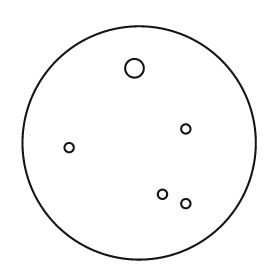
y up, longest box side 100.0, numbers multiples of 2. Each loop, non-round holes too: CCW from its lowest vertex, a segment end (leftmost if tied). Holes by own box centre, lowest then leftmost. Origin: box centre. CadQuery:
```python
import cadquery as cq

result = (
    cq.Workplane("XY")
    .moveTo(0.0, 0.0)
    .circle(50.0)
    .moveTo(20.0, -26.0)
    .circle(2.0)
    .moveTo(10.0, -22.0)
    .circle(2.0)
    .moveTo(-30.0, -2.0)
    .circle(2.0)
    .moveTo(20.0, 6.0)
    .circle(2.0)
    .moveTo(-2.0, 32.0)
    .circle(4.0)
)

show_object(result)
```